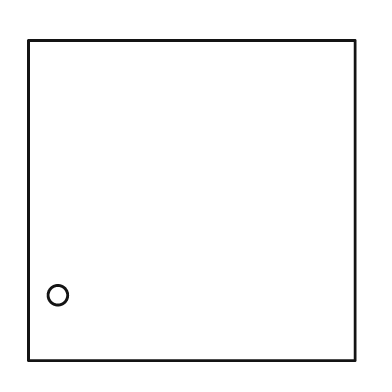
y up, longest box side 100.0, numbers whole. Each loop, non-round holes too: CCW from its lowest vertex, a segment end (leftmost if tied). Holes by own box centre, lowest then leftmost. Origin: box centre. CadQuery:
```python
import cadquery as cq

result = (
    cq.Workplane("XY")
    .moveTo(-50.0, -49.0)
    .lineTo(50.0, -49.0)
    .lineTo(50.0, 49.0)
    .lineTo(-50.0, 49.0)
    .close()
    .moveTo(-41.0, -29.0)
    .circle(3.0)
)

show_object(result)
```